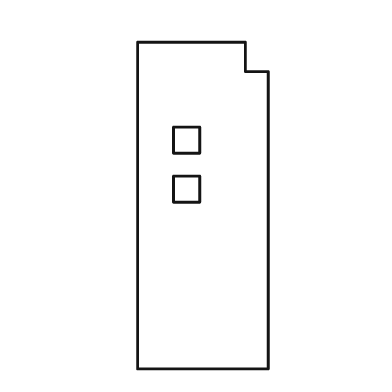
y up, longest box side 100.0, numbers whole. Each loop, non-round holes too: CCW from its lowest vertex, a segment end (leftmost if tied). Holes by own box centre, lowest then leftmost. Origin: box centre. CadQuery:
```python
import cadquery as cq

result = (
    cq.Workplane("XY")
    .moveTo(-20.0, -50.0)
    .lineTo(20.0, -50.0)
    .lineTo(20.0, 41.0)
    .lineTo(13.0, 41.0)
    .lineTo(13.0, 50.0)
    .lineTo(-20.0, 50.0)
    .close()
    .moveTo(-9.0, 1.0)
    .lineTo(-1.0, 1.0)
    .lineTo(-1.0, 9.0)
    .lineTo(-9.0, 9.0)
    .close()
    .moveTo(-9.0, 16.0)
    .lineTo(-1.0, 16.0)
    .lineTo(-1.0, 24.0)
    .lineTo(-9.0, 24.0)
    .close()
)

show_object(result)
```